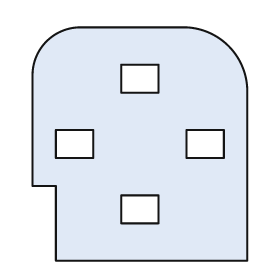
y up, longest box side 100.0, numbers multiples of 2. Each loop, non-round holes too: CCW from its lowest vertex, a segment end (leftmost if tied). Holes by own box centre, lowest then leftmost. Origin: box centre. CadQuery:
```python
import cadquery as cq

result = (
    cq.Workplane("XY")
    .moveTo(-36.0, -50.0)
    .lineTo(46.0, -50.0)
    .lineTo(46.0, 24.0)
    .threePointArc((38.0, 42.0), (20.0, 50.0))
    .lineTo(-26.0, 50.0)
    .threePointArc((-40.0, 44.0), (-46.0, 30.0))
    .lineTo(-46.0, -18.0)
    .lineTo(-36.0, -18.0)
    .close()
    .moveTo(-8.0, -34.0)
    .lineTo(8.0, -34.0)
    .lineTo(8.0, -22.0)
    .lineTo(-8.0, -22.0)
    .close()
    .moveTo(-36.0, -6.0)
    .lineTo(-20.0, -6.0)
    .lineTo(-20.0, 6.0)
    .lineTo(-36.0, 6.0)
    .close()
    .moveTo(20.0, -6.0)
    .lineTo(36.0, -6.0)
    .lineTo(36.0, 6.0)
    .lineTo(20.0, 6.0)
    .close()
    .moveTo(-8.0, 22.0)
    .lineTo(8.0, 22.0)
    .lineTo(8.0, 34.0)
    .lineTo(-8.0, 34.0)
    .close()
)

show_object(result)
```